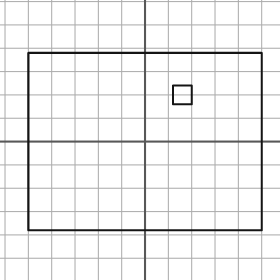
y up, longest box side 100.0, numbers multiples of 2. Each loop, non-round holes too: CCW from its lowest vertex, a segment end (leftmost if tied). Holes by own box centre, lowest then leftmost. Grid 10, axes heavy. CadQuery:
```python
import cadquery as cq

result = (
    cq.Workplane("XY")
    .moveTo(-50.0, -38.0)
    .lineTo(50.0, -38.0)
    .lineTo(50.0, 38.0)
    .lineTo(-50.0, 38.0)
    .close()
    .moveTo(12.0, 16.0)
    .lineTo(20.0, 16.0)
    .lineTo(20.0, 24.0)
    .lineTo(12.0, 24.0)
    .close()
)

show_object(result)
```